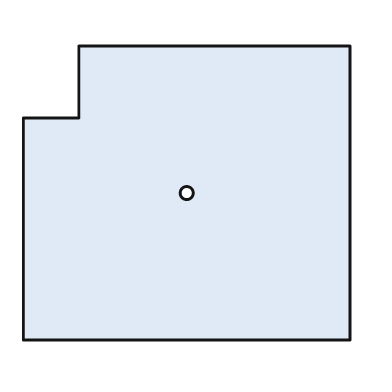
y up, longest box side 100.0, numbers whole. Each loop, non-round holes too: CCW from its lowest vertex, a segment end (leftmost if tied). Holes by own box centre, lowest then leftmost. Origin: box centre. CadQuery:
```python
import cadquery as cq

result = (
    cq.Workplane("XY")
    .moveTo(-50.0, -45.0)
    .lineTo(50.0, -45.0)
    .lineTo(50.0, 45.0)
    .lineTo(-33.0, 45.0)
    .lineTo(-33.0, 23.0)
    .lineTo(-50.0, 23.0)
    .close()
    .moveTo(0.0, 0.0)
    .circle(2.0)
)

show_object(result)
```